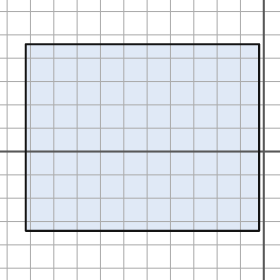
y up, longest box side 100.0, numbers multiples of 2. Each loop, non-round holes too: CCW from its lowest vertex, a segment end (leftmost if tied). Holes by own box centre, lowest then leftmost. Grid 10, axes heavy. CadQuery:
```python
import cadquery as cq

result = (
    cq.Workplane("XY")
    .moveTo(-102.0, -34.0)
    .lineTo(-2.0, -34.0)
    .lineTo(-2.0, 46.0)
    .lineTo(-102.0, 46.0)
    .close()
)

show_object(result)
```